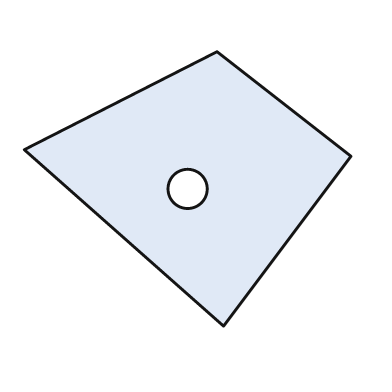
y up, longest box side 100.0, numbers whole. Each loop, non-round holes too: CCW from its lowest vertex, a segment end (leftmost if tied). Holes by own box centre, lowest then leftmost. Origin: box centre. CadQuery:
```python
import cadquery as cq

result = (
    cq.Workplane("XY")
    .moveTo(11.0, -42.0)
    .lineTo(50.0, 10.0)
    .lineTo(9.0, 42.0)
    .lineTo(-50.0, 12.0)
    .close()
    .moveTo(0.0, 0.0)
    .circle(6.0)
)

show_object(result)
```